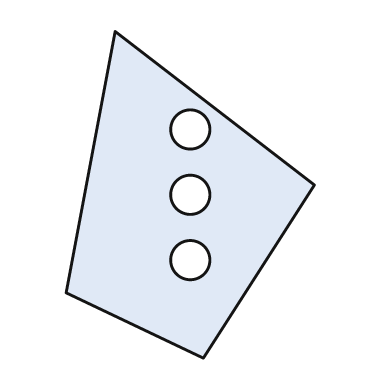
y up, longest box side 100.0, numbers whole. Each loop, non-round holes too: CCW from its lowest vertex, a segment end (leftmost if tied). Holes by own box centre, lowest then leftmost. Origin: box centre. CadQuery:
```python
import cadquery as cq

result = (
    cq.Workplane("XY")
    .moveTo(4.0, -50.0)
    .lineTo(38.0, 3.0)
    .lineTo(-23.0, 50.0)
    .lineTo(-38.0, -30.0)
    .close()
    .moveTo(0.0, -20.0)
    .circle(6.0)
    .moveTo(0.0, 0.0)
    .circle(6.0)
    .moveTo(0.0, 20.0)
    .circle(6.0)
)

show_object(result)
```